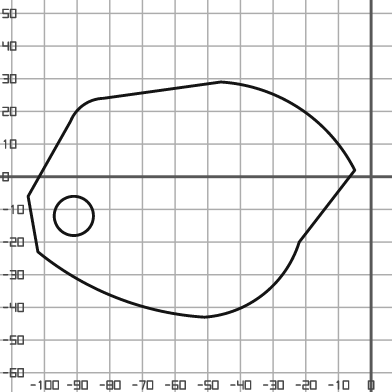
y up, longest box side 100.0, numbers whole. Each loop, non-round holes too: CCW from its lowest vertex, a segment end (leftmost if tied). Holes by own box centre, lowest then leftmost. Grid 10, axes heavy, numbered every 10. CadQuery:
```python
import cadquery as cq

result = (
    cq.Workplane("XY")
    .moveTo(-51.0, -43.0)
    .threePointArc((-33.0, -36.0), (-22.0, -20.0))
    .lineTo(-5.0, 2.0)
    .threePointArc((-22.0, 21.0), (-46.0, 29.0))
    .lineTo(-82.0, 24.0)
    .threePointArc((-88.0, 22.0), (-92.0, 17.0))
    .lineTo(-105.0, -6.0)
    .lineTo(-102.0, -23.0)
    .threePointArc((-78.0, -37.0), (-51.0, -43.0))
    .close()
    .moveTo(-91.0, -12.0)
    .circle(6.0)
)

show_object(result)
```